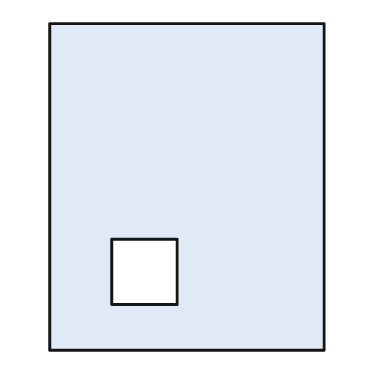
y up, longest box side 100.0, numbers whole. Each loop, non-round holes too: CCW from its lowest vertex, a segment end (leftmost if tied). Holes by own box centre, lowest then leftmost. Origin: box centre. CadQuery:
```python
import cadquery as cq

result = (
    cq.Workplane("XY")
    .moveTo(-42.0, -50.0)
    .lineTo(42.0, -50.0)
    .lineTo(42.0, 50.0)
    .lineTo(-42.0, 50.0)
    .close()
    .moveTo(-23.0, -36.0)
    .lineTo(-3.0, -36.0)
    .lineTo(-3.0, -16.0)
    .lineTo(-23.0, -16.0)
    .close()
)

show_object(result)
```